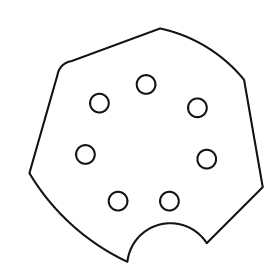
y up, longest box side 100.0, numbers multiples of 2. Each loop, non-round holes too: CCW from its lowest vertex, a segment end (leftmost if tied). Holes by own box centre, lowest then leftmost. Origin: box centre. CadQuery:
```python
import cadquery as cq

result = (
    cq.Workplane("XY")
    .moveTo(-8.0, -50.0)
    .threePointArc((6.0, -34.0), (26.0, -42.0))
    .lineTo(50.0, -18.0)
    .lineTo(42.0, 28.0)
    .threePointArc((26.0, 42.0), (6.0, 50.0))
    .lineTo(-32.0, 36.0)
    .threePointArc((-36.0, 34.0), (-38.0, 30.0))
    .lineTo(-50.0, -12.0)
    .threePointArc((-32.0, -34.0), (-8.0, -50.0))
    .close()
    .moveTo(-12.0, -24.0)
    .circle(4.0)
    .moveTo(10.0, -24.0)
    .circle(4.0)
    .moveTo(26.0, -6.0)
    .circle(4.0)
    .moveTo(-26.0, -4.0)
    .circle(4.0)
    .moveTo(22.0, 16.0)
    .circle(4.0)
    .moveTo(-20.0, 18.0)
    .circle(4.0)
    .moveTo(0.0, 26.0)
    .circle(4.0)
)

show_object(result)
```